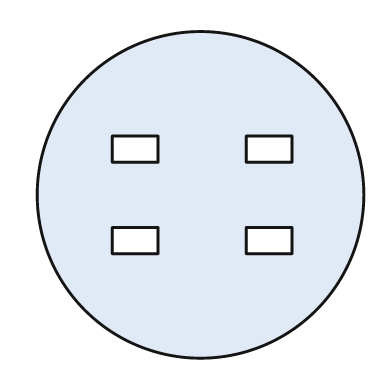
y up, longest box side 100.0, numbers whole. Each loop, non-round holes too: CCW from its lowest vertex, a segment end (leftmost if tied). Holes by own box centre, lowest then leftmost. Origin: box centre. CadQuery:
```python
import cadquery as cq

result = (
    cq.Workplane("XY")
    .moveTo(0.0, 0.0)
    .circle(50.0)
    .moveTo(-27.0, -18.0)
    .lineTo(-13.0, -18.0)
    .lineTo(-13.0, -10.0)
    .lineTo(-27.0, -10.0)
    .close()
    .moveTo(14.0, -18.0)
    .lineTo(28.0, -18.0)
    .lineTo(28.0, -10.0)
    .lineTo(14.0, -10.0)
    .close()
    .moveTo(-27.0, 10.0)
    .lineTo(-13.0, 10.0)
    .lineTo(-13.0, 18.0)
    .lineTo(-27.0, 18.0)
    .close()
    .moveTo(14.0, 10.0)
    .lineTo(28.0, 10.0)
    .lineTo(28.0, 18.0)
    .lineTo(14.0, 18.0)
    .close()
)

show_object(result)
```